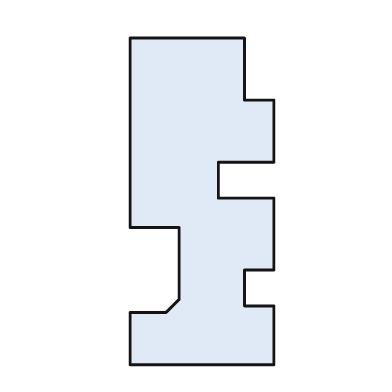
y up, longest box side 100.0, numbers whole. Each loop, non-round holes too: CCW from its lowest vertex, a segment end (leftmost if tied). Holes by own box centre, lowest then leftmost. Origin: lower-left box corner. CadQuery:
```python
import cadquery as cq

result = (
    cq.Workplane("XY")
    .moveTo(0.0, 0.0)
    .lineTo(44.0, 0.0)
    .lineTo(44.0, 18.0)
    .lineTo(35.0, 18.0)
    .lineTo(35.0, 29.0)
    .lineTo(44.0, 29.0)
    .lineTo(44.0, 51.0)
    .lineTo(27.0, 51.0)
    .lineTo(27.0, 62.0)
    .lineTo(44.0, 62.0)
    .lineTo(44.0, 81.0)
    .lineTo(35.0, 81.0)
    .lineTo(35.0, 100.0)
    .lineTo(0.0, 100.0)
    .lineTo(0.0, 42.0)
    .lineTo(15.0, 42.0)
    .lineTo(15.0, 20.0)
    .lineTo(11.0, 16.0)
    .lineTo(0.0, 16.0)
    .close()
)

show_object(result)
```